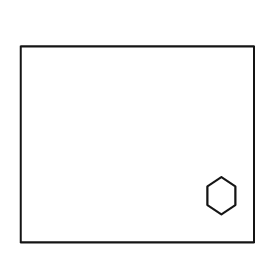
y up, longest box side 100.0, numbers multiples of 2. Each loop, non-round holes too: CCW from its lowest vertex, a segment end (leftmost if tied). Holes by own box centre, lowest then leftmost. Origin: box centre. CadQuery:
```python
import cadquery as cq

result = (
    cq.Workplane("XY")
    .moveTo(-50.0, -42.0)
    .lineTo(50.0, -42.0)
    .lineTo(50.0, 42.0)
    .lineTo(-50.0, 42.0)
    .close()
    .moveTo(36.0, -30.0)
    .lineTo(42.0, -26.0)
    .lineTo(42.0, -18.0)
    .lineTo(36.0, -14.0)
    .lineTo(30.0, -18.0)
    .lineTo(30.0, -26.0)
    .close()
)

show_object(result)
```